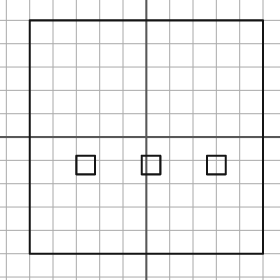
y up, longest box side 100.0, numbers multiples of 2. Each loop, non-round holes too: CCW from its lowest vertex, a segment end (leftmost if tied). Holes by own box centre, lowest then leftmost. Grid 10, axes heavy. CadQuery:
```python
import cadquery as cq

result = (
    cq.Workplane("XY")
    .moveTo(-50.0, -50.0)
    .lineTo(50.0, -50.0)
    .lineTo(50.0, 50.0)
    .lineTo(-50.0, 50.0)
    .close()
    .moveTo(-30.0, -16.0)
    .lineTo(-22.0, -16.0)
    .lineTo(-22.0, -8.0)
    .lineTo(-30.0, -8.0)
    .close()
    .moveTo(-2.0, -16.0)
    .lineTo(6.0, -16.0)
    .lineTo(6.0, -8.0)
    .lineTo(-2.0, -8.0)
    .close()
    .moveTo(26.0, -16.0)
    .lineTo(34.0, -16.0)
    .lineTo(34.0, -8.0)
    .lineTo(26.0, -8.0)
    .close()
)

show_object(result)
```